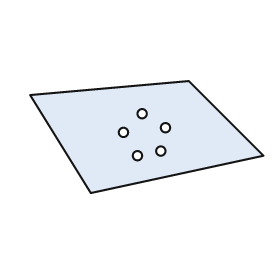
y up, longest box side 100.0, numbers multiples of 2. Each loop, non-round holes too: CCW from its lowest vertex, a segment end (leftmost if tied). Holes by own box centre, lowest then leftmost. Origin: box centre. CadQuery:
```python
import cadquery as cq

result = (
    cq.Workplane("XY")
    .moveTo(-24.0, -24.0)
    .lineTo(50.0, -8.0)
    .lineTo(18.0, 24.0)
    .lineTo(-50.0, 18.0)
    .close()
    .moveTo(-4.0, -8.0)
    .circle(2.0)
    .moveTo(6.0, -6.0)
    .circle(2.0)
    .moveTo(-10.0, 2.0)
    .circle(2.0)
    .moveTo(8.0, 4.0)
    .circle(2.0)
    .moveTo(-2.0, 10.0)
    .circle(2.0)
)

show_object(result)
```